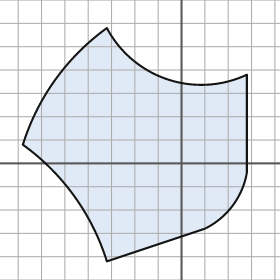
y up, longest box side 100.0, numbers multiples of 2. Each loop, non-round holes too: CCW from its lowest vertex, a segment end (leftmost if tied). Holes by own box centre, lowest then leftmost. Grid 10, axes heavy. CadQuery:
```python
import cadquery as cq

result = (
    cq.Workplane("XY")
    .moveTo(-32.0, -42.0)
    .lineTo(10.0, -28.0)
    .threePointArc((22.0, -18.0), (28.0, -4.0))
    .lineTo(28.0, 38.0)
    .threePointArc((-6.0, 36.0), (-32.0, 58.0))
    .threePointArc((-54.0, 36.0), (-68.0, 8.0))
    .threePointArc((-46.0, -14.0), (-32.0, -42.0))
    .close()
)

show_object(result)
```